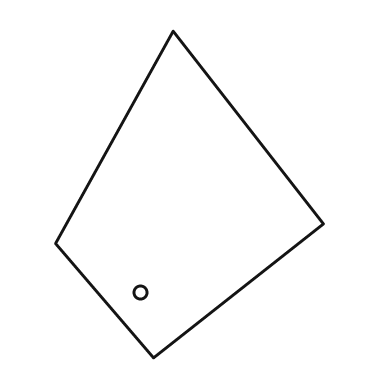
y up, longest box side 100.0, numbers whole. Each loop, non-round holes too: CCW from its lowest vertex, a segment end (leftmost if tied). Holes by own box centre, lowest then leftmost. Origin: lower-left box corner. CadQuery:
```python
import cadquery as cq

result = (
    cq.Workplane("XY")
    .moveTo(30.0, 0.0)
    .lineTo(82.0, 41.0)
    .lineTo(36.0, 100.0)
    .lineTo(0.0, 35.0)
    .close()
    .moveTo(26.0, 20.0)
    .circle(2.0)
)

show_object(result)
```